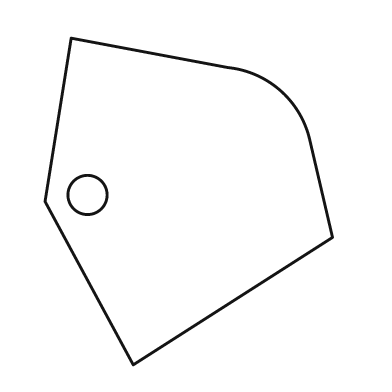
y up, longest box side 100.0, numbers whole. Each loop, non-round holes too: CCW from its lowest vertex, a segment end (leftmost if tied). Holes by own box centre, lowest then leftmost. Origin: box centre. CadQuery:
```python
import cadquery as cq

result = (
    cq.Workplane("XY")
    .moveTo(-17.0, -50.0)
    .lineTo(44.0, -11.0)
    .lineTo(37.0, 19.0)
    .threePointArc((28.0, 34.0), (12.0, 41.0))
    .lineTo(-36.0, 50.0)
    .lineTo(-44.0, 0.0)
    .close()
    .moveTo(-31.0, 2.0)
    .circle(6.0)
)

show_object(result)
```